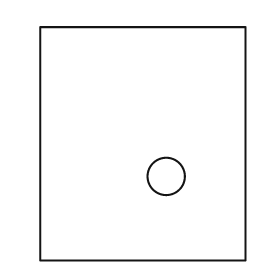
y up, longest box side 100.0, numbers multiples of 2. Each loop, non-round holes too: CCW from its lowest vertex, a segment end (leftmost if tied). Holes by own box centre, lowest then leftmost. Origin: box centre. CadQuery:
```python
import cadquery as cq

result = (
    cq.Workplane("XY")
    .moveTo(-44.0, -50.0)
    .lineTo(44.0, -50.0)
    .lineTo(44.0, 50.0)
    .lineTo(-44.0, 50.0)
    .close()
    .moveTo(10.0, -14.0)
    .circle(8.0)
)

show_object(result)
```